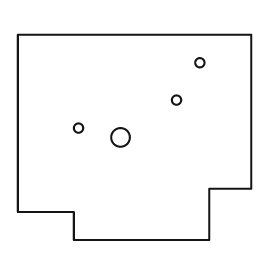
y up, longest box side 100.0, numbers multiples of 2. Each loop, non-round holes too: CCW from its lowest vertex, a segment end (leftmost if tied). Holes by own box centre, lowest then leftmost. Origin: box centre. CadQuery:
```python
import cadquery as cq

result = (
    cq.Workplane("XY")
    .moveTo(-26.0, -44.0)
    .lineTo(32.0, -44.0)
    .lineTo(32.0, -22.0)
    .lineTo(50.0, -22.0)
    .lineTo(50.0, 44.0)
    .lineTo(-50.0, 44.0)
    .lineTo(-50.0, -32.0)
    .lineTo(-26.0, -32.0)
    .close()
    .moveTo(-6.0, 0.0)
    .circle(4.0)
    .moveTo(-24.0, 4.0)
    .circle(2.0)
    .moveTo(18.0, 16.0)
    .circle(2.0)
    .moveTo(28.0, 32.0)
    .circle(2.0)
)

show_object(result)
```